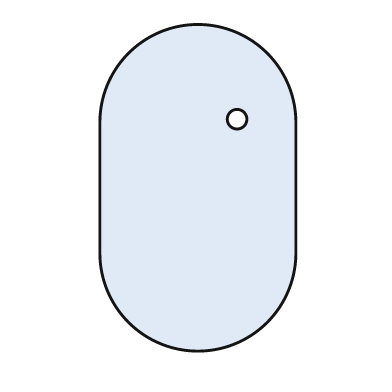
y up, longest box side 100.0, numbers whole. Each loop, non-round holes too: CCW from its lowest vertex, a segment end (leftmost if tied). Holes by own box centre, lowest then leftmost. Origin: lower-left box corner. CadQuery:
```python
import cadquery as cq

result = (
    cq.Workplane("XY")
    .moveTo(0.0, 30.0)
    .threePointArc((30.0, 0.0), (60.0, 30.0))
    .lineTo(60.0, 70.0)
    .threePointArc((30.0, 100.0), (0.0, 70.0))
    .close()
    .moveTo(42.0, 71.0)
    .circle(3.0)
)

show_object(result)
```